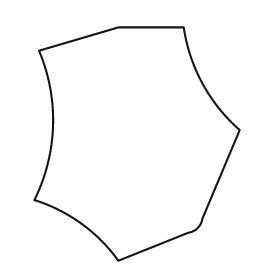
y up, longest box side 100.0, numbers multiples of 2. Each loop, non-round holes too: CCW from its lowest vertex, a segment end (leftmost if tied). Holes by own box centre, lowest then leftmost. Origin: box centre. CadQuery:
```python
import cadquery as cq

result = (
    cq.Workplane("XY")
    .moveTo(-8.0, -50.0)
    .lineTo(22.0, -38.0)
    .threePointArc((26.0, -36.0), (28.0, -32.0))
    .lineTo(44.0, 6.0)
    .threePointArc((28.0, 26.0), (20.0, 50.0))
    .lineTo(-8.0, 50.0)
    .lineTo(-42.0, 40.0)
    .threePointArc((-36.0, 8.0), (-44.0, -24.0))
    .threePointArc((-24.0, -34.0), (-8.0, -50.0))
    .close()
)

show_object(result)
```